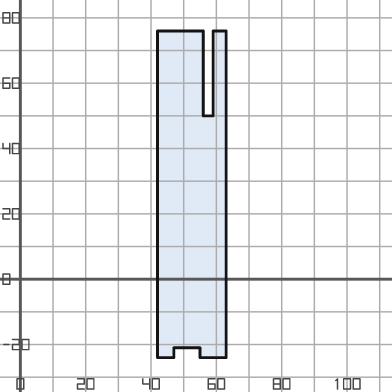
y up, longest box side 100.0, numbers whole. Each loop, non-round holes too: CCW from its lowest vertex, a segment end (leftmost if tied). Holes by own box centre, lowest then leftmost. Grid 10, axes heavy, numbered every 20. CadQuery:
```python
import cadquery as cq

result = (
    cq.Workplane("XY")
    .moveTo(42.0, -24.0)
    .lineTo(47.0, -24.0)
    .lineTo(47.0, -21.0)
    .lineTo(55.0, -21.0)
    .lineTo(55.0, -24.0)
    .lineTo(63.0, -24.0)
    .lineTo(63.0, 76.0)
    .lineTo(59.0, 76.0)
    .lineTo(59.0, 50.0)
    .lineTo(56.0, 50.0)
    .lineTo(56.0, 76.0)
    .lineTo(42.0, 76.0)
    .close()
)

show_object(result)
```